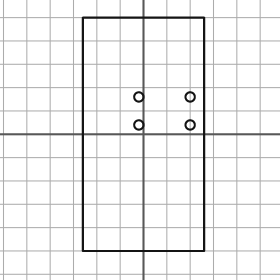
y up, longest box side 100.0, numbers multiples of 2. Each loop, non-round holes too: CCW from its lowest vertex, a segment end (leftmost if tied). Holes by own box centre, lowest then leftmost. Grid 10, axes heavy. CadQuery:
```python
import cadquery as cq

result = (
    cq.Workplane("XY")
    .moveTo(-26.0, -50.0)
    .lineTo(26.0, -50.0)
    .lineTo(26.0, 50.0)
    .lineTo(-26.0, 50.0)
    .close()
    .moveTo(-2.0, 4.0)
    .circle(2.0)
    .moveTo(20.0, 4.0)
    .circle(2.0)
    .moveTo(-2.0, 16.0)
    .circle(2.0)
    .moveTo(20.0, 16.0)
    .circle(2.0)
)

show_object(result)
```